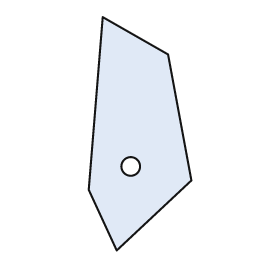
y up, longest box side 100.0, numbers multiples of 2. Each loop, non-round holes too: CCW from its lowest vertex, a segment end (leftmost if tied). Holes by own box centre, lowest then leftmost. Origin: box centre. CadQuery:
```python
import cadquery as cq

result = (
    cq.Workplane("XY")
    .moveTo(-10.0, -50.0)
    .lineTo(22.0, -20.0)
    .lineTo(12.0, 34.0)
    .lineTo(-16.0, 50.0)
    .lineTo(-22.0, -24.0)
    .close()
    .moveTo(-4.0, -14.0)
    .circle(4.0)
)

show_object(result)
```